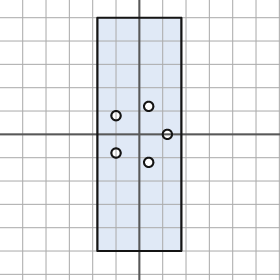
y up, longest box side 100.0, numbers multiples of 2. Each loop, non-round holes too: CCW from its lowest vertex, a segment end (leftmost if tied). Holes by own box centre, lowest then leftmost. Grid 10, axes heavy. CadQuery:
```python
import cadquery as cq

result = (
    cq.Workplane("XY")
    .moveTo(-18.0, -50.0)
    .lineTo(18.0, -50.0)
    .lineTo(18.0, 50.0)
    .lineTo(-18.0, 50.0)
    .close()
    .moveTo(4.0, -12.0)
    .circle(2.0)
    .moveTo(-10.0, -8.0)
    .circle(2.0)
    .moveTo(12.0, 0.0)
    .circle(2.0)
    .moveTo(-10.0, 8.0)
    .circle(2.0)
    .moveTo(4.0, 12.0)
    .circle(2.0)
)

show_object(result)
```